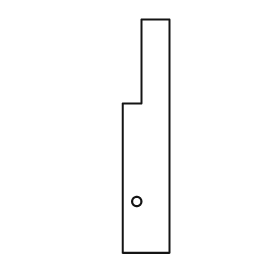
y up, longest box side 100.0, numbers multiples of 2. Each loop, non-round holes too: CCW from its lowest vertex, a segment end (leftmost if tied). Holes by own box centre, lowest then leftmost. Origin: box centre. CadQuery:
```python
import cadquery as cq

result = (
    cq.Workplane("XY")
    .moveTo(-10.0, -50.0)
    .lineTo(10.0, -50.0)
    .lineTo(10.0, 50.0)
    .lineTo(-2.0, 50.0)
    .lineTo(-2.0, 14.0)
    .lineTo(-10.0, 14.0)
    .close()
    .moveTo(-4.0, -28.0)
    .circle(2.0)
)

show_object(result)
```